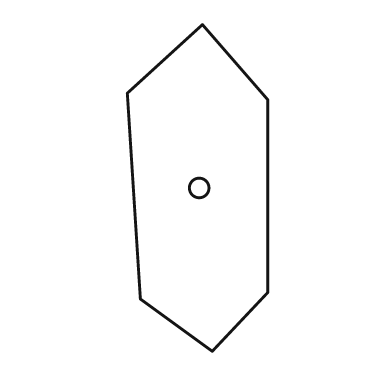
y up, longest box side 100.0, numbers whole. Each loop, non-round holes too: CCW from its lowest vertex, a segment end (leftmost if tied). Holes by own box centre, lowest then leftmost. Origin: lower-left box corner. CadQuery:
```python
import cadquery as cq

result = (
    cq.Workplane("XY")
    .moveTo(26.0, 0.0)
    .lineTo(43.0, 18.0)
    .lineTo(43.0, 77.0)
    .lineTo(23.0, 100.0)
    .lineTo(0.0, 79.0)
    .lineTo(4.0, 16.0)
    .close()
    .moveTo(22.0, 50.0)
    .circle(3.0)
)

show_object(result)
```